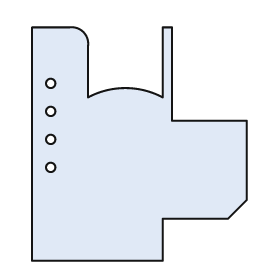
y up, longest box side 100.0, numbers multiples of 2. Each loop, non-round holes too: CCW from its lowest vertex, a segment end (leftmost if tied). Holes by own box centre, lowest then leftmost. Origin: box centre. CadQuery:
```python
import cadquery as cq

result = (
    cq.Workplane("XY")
    .moveTo(-46.0, -50.0)
    .lineTo(10.0, -50.0)
    .lineTo(10.0, -32.0)
    .lineTo(38.0, -32.0)
    .lineTo(46.0, -24.0)
    .lineTo(46.0, 10.0)
    .lineTo(14.0, 10.0)
    .lineTo(14.0, 50.0)
    .lineTo(10.0, 50.0)
    .lineTo(10.0, 20.0)
    .threePointArc((-6.0, 24.0), (-22.0, 20.0))
    .lineTo(-22.0, 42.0)
    .threePointArc((-24.0, 48.0), (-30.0, 50.0))
    .lineTo(-46.0, 50.0)
    .close()
    .moveTo(-38.0, -10.0)
    .circle(2.0)
    .moveTo(-38.0, 2.0)
    .circle(2.0)
    .moveTo(-38.0, 14.0)
    .circle(2.0)
    .moveTo(-38.0, 26.0)
    .circle(2.0)
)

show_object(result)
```